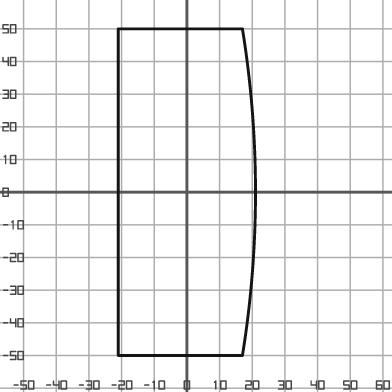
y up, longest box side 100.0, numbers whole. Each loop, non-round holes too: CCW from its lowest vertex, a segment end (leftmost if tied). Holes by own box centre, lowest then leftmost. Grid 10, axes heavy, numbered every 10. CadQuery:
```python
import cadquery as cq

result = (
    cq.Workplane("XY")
    .moveTo(-21.0, -50.0)
    .lineTo(17.0, -50.0)
    .threePointArc((21.0, 0.0), (17.0, 50.0))
    .lineTo(-21.0, 50.0)
    .close()
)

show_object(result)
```